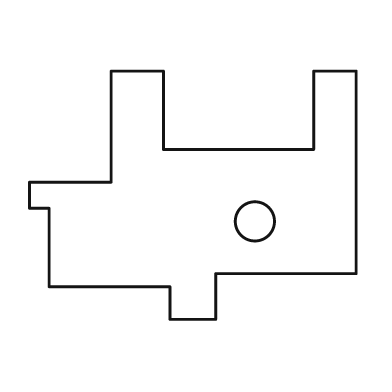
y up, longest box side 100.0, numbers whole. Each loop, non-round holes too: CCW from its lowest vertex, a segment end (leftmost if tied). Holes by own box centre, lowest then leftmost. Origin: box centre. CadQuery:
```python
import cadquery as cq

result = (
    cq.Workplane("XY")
    .moveTo(-7.0, -38.0)
    .lineTo(7.0, -38.0)
    .lineTo(7.0, -24.0)
    .lineTo(50.0, -24.0)
    .lineTo(50.0, 38.0)
    .lineTo(37.0, 38.0)
    .lineTo(37.0, 14.0)
    .lineTo(-9.0, 14.0)
    .lineTo(-9.0, 38.0)
    .lineTo(-25.0, 38.0)
    .lineTo(-25.0, 4.0)
    .lineTo(-50.0, 4.0)
    .lineTo(-50.0, -4.0)
    .lineTo(-44.0, -4.0)
    .lineTo(-44.0, -28.0)
    .lineTo(-7.0, -28.0)
    .close()
    .moveTo(19.0, -8.0)
    .circle(6.0)
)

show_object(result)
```